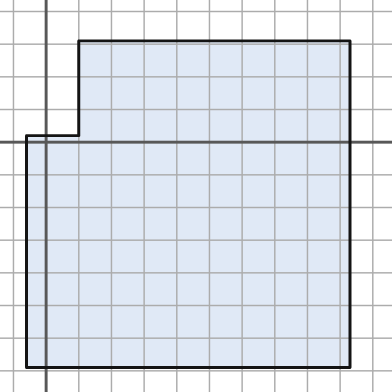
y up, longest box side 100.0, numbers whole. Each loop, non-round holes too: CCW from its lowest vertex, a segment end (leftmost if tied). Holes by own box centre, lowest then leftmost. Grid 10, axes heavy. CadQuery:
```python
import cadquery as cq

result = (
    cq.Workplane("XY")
    .moveTo(-6.0, -69.0)
    .lineTo(93.0, -69.0)
    .lineTo(93.0, 31.0)
    .lineTo(10.0, 31.0)
    .lineTo(10.0, 2.0)
    .lineTo(-6.0, 2.0)
    .close()
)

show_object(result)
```